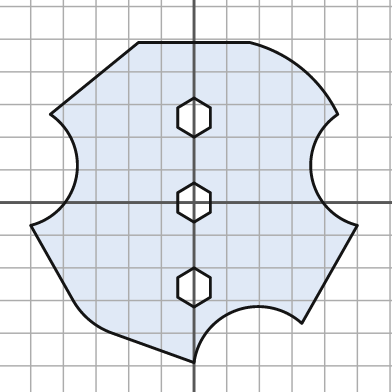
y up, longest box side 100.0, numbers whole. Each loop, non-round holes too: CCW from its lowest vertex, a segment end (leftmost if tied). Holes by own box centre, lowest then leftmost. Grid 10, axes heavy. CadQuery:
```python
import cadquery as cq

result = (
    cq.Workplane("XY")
    .moveTo(0.0, -49.0)
    .threePointArc((13.0, -33.0), (33.0, -37.0))
    .lineTo(50.0, -7.0)
    .threePointArc((36.0, 8.0), (44.0, 27.0))
    .threePointArc((33.0, 41.0), (17.0, 49.0))
    .lineTo(-17.0, 49.0)
    .lineTo(-44.0, 27.0)
    .threePointArc((-36.0, 8.0), (-50.0, -7.0))
    .lineTo(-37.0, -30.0)
    .threePointArc((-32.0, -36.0), (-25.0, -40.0))
    .close()
    .moveTo(0.0, -32.0)
    .lineTo(5.0, -29.0)
    .lineTo(5.0, -23.0)
    .lineTo(0.0, -20.0)
    .lineTo(-5.0, -23.0)
    .lineTo(-5.0, -29.0)
    .close()
    .moveTo(0.0, -6.0)
    .lineTo(5.0, -3.0)
    .lineTo(5.0, 3.0)
    .lineTo(0.0, 6.0)
    .lineTo(-5.0, 3.0)
    .lineTo(-5.0, -3.0)
    .close()
    .moveTo(0.0, 20.0)
    .lineTo(5.0, 23.0)
    .lineTo(5.0, 29.0)
    .lineTo(0.0, 32.0)
    .lineTo(-5.0, 29.0)
    .lineTo(-5.0, 23.0)
    .close()
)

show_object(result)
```